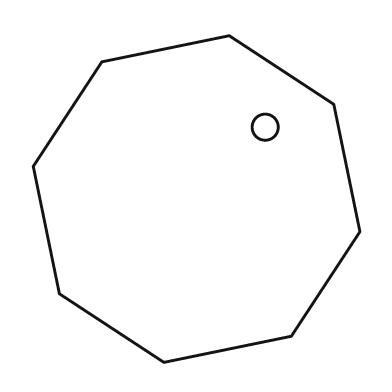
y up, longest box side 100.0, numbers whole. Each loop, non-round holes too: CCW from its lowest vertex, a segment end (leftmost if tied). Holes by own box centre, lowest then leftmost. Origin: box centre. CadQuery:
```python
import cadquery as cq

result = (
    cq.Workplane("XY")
    .moveTo(-10.0, -50.0)
    .lineTo(29.0, -42.0)
    .lineTo(50.0, -10.0)
    .lineTo(42.0, 29.0)
    .lineTo(10.0, 50.0)
    .lineTo(-29.0, 42.0)
    .lineTo(-50.0, 10.0)
    .lineTo(-42.0, -29.0)
    .close()
    .moveTo(21.0, 22.0)
    .circle(4.0)
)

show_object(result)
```